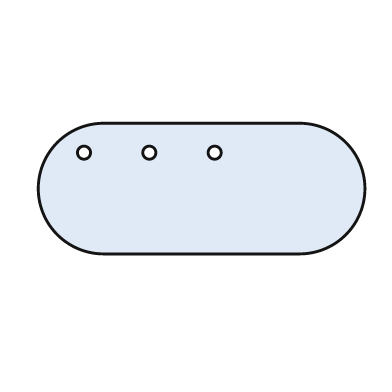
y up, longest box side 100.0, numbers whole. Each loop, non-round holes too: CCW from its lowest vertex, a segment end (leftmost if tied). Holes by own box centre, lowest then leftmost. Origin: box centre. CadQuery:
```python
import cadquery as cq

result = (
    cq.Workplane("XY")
    .moveTo(-30.0, -20.0)
    .lineTo(30.0, -20.0)
    .threePointArc((50.0, 0.0), (30.0, 20.0))
    .lineTo(-30.0, 20.0)
    .threePointArc((-50.0, 0.0), (-30.0, -20.0))
    .close()
    .moveTo(-36.0, 11.0)
    .circle(2.0)
    .moveTo(-16.0, 11.0)
    .circle(2.0)
    .moveTo(4.0, 11.0)
    .circle(2.0)
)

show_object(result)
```